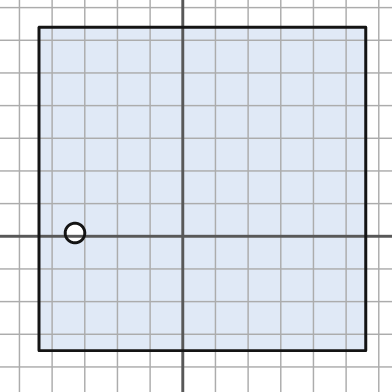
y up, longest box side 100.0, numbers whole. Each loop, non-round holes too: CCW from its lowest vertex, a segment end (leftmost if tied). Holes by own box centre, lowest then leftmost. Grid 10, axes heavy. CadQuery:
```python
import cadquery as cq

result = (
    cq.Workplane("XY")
    .moveTo(-44.0, -35.0)
    .lineTo(56.0, -35.0)
    .lineTo(56.0, 64.0)
    .lineTo(-44.0, 64.0)
    .close()
    .moveTo(-33.0, 1.0)
    .circle(3.0)
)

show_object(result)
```